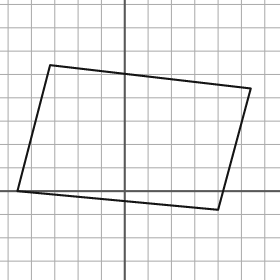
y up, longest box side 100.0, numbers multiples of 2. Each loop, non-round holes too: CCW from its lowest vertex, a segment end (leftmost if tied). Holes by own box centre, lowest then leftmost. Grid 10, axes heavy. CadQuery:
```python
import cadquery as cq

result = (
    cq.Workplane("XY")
    .moveTo(40.0, -8.0)
    .lineTo(54.0, 44.0)
    .lineTo(-32.0, 54.0)
    .lineTo(-46.0, 0.0)
    .close()
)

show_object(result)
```